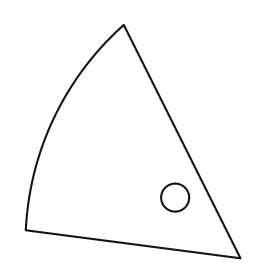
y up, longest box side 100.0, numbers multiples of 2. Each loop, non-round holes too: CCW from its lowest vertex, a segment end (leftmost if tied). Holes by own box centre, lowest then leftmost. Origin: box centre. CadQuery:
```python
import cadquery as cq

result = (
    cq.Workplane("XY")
    .moveTo(46.0, -50.0)
    .lineTo(-4.0, 50.0)
    .threePointArc((-34.0, 10.0), (-46.0, -38.0))
    .close()
    .moveTo(18.0, -24.0)
    .circle(6.0)
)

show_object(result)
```